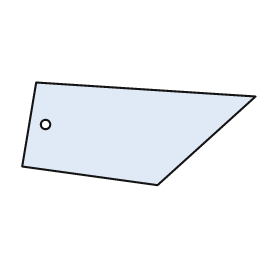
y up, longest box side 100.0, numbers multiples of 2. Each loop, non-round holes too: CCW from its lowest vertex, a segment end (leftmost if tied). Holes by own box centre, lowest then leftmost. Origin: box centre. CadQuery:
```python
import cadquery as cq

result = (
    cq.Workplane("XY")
    .moveTo(8.0, -22.0)
    .lineTo(50.0, 16.0)
    .lineTo(-44.0, 22.0)
    .lineTo(-50.0, -14.0)
    .close()
    .moveTo(-40.0, 4.0)
    .circle(2.0)
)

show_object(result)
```